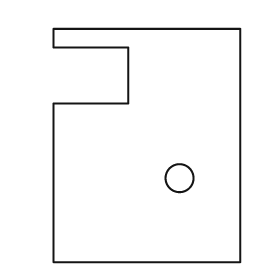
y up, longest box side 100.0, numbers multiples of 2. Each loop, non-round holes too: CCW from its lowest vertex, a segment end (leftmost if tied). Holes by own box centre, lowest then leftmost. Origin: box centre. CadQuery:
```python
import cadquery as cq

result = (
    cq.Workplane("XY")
    .moveTo(-40.0, -50.0)
    .lineTo(40.0, -50.0)
    .lineTo(40.0, 50.0)
    .lineTo(-40.0, 50.0)
    .lineTo(-40.0, 42.0)
    .lineTo(-8.0, 42.0)
    .lineTo(-8.0, 18.0)
    .lineTo(-40.0, 18.0)
    .close()
    .moveTo(14.0, -14.0)
    .circle(6.0)
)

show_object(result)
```